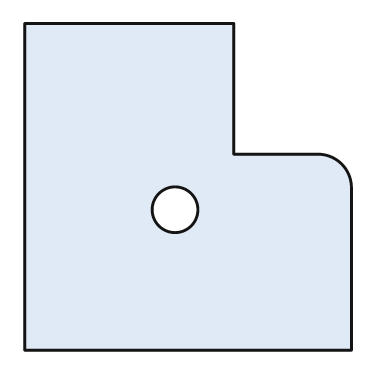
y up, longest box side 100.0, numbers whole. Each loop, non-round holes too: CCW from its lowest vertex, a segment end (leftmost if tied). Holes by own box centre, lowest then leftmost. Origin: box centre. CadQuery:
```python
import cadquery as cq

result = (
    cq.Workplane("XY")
    .moveTo(-50.0, -50.0)
    .lineTo(50.0, -50.0)
    .lineTo(50.0, 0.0)
    .threePointArc((47.0, 7.0), (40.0, 10.0))
    .lineTo(14.0, 10.0)
    .lineTo(14.0, 50.0)
    .lineTo(-50.0, 50.0)
    .close()
    .moveTo(-4.0, -7.0)
    .circle(7.0)
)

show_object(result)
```